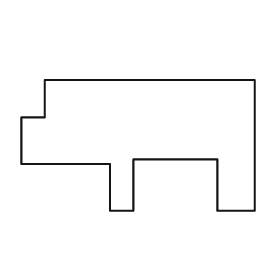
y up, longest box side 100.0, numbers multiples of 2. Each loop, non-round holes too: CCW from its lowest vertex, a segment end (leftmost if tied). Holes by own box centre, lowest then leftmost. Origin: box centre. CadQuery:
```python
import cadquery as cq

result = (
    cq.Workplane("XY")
    .moveTo(-12.0, -28.0)
    .lineTo(-2.0, -28.0)
    .lineTo(-2.0, -6.0)
    .lineTo(34.0, -6.0)
    .lineTo(34.0, -28.0)
    .lineTo(50.0, -28.0)
    .lineTo(50.0, 28.0)
    .lineTo(-40.0, 28.0)
    .lineTo(-40.0, 12.0)
    .lineTo(-50.0, 12.0)
    .lineTo(-50.0, -8.0)
    .lineTo(-12.0, -8.0)
    .close()
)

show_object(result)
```